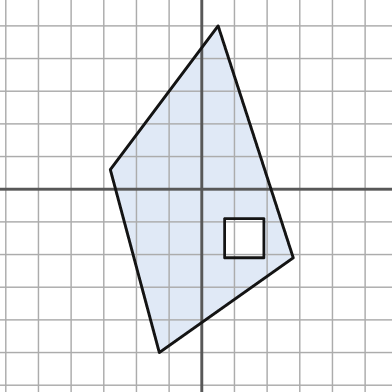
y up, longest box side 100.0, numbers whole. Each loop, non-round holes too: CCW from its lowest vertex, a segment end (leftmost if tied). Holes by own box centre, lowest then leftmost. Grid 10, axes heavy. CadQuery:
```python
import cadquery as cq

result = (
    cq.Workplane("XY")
    .moveTo(-13.0, -50.0)
    .lineTo(28.0, -21.0)
    .lineTo(5.0, 50.0)
    .lineTo(-28.0, 6.0)
    .close()
    .moveTo(7.0, -21.0)
    .lineTo(19.0, -21.0)
    .lineTo(19.0, -9.0)
    .lineTo(7.0, -9.0)
    .close()
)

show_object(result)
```